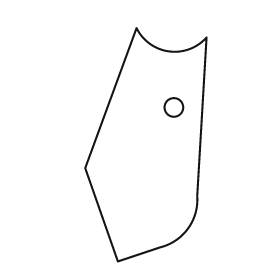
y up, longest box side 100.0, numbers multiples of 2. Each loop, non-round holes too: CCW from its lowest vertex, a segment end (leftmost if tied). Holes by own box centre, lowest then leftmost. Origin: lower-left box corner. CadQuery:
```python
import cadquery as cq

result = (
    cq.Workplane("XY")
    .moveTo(14.0, 0.0)
    .lineTo(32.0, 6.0)
    .threePointArc((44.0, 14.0), (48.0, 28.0))
    .lineTo(52.0, 96.0)
    .threePointArc((36.0, 90.0), (22.0, 100.0))
    .lineTo(0.0, 40.0)
    .close()
    .moveTo(38.0, 66.0)
    .circle(4.0)
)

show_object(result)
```